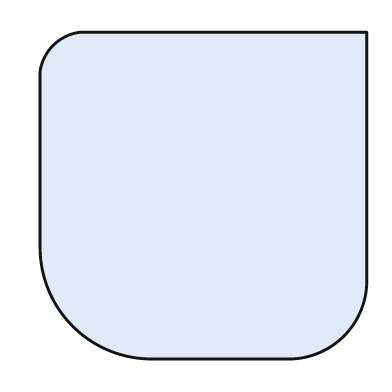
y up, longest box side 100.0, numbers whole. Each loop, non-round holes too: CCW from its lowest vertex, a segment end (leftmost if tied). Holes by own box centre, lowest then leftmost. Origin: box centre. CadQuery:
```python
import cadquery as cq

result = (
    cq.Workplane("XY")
    .moveTo(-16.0, -50.0)
    .lineTo(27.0, -50.0)
    .threePointArc((43.0, -43.0), (50.0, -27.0))
    .lineTo(50.0, 50.0)
    .lineTo(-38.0, 50.0)
    .threePointArc((-46.0, 46.0), (-50.0, 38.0))
    .lineTo(-50.0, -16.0)
    .threePointArc((-40.0, -40.0), (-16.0, -50.0))
    .close()
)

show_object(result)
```